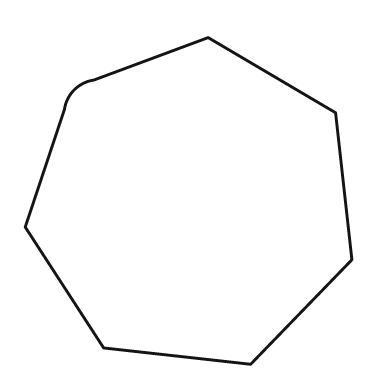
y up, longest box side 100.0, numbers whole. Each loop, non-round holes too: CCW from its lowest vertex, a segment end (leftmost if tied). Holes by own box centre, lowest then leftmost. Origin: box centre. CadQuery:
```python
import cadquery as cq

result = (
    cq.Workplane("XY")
    .moveTo(19.0, -50.0)
    .lineTo(50.0, -18.0)
    .lineTo(45.0, 27.0)
    .lineTo(6.0, 50.0)
    .lineTo(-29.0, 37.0)
    .threePointArc((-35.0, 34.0), (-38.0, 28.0))
    .lineTo(-50.0, -8.0)
    .lineTo(-26.0, -45.0)
    .close()
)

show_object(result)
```